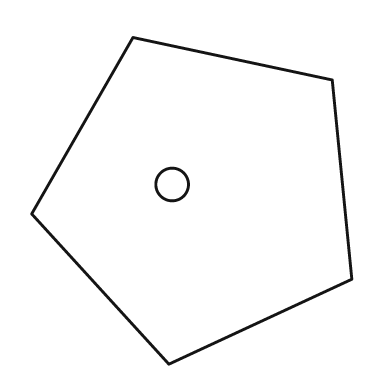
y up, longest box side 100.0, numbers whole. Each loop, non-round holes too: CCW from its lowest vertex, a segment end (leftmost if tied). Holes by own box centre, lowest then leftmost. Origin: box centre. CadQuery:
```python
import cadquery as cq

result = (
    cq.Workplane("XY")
    .moveTo(-7.0, -50.0)
    .lineTo(49.0, -24.0)
    .lineTo(43.0, 37.0)
    .lineTo(-18.0, 50.0)
    .lineTo(-49.0, -4.0)
    .close()
    .moveTo(-6.0, 5.0)
    .circle(5.0)
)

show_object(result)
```